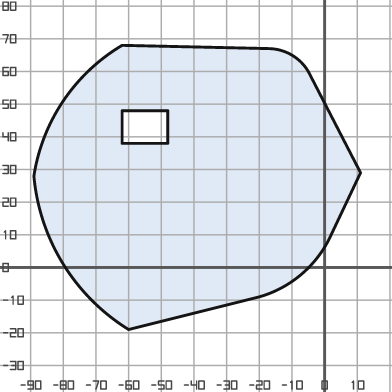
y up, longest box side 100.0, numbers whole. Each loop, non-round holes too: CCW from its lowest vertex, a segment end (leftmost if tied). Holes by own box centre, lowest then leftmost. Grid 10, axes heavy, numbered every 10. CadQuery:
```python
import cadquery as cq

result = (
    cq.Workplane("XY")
    .moveTo(-60.0, -19.0)
    .lineTo(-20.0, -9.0)
    .threePointArc((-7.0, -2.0), (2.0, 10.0))
    .lineTo(11.0, 29.0)
    .lineTo(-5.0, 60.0)
    .threePointArc((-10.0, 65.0), (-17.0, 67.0))
    .lineTo(-62.0, 68.0)
    .threePointArc((-80.0, 51.0), (-89.0, 28.0))
    .threePointArc((-80.0, 1.0), (-60.0, -19.0))
    .close()
    .moveTo(-62.0, 38.0)
    .lineTo(-48.0, 38.0)
    .lineTo(-48.0, 48.0)
    .lineTo(-62.0, 48.0)
    .close()
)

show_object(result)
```